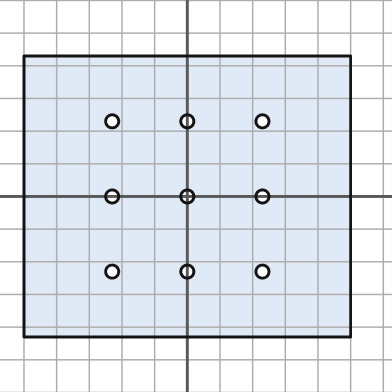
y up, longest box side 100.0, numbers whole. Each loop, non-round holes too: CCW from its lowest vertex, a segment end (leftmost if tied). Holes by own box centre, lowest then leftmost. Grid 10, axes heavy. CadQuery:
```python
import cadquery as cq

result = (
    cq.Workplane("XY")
    .moveTo(-50.0, -43.0)
    .lineTo(50.0, -43.0)
    .lineTo(50.0, 43.0)
    .lineTo(-50.0, 43.0)
    .close()
    .moveTo(-23.0, -23.0)
    .circle(2.0)
    .moveTo(0.0, -23.0)
    .circle(2.0)
    .moveTo(23.0, -23.0)
    .circle(2.0)
    .moveTo(-23.0, 0.0)
    .circle(2.0)
    .moveTo(0.0, 0.0)
    .circle(2.0)
    .moveTo(23.0, 0.0)
    .circle(2.0)
    .moveTo(-23.0, 23.0)
    .circle(2.0)
    .moveTo(0.0, 23.0)
    .circle(2.0)
    .moveTo(23.0, 23.0)
    .circle(2.0)
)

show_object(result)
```